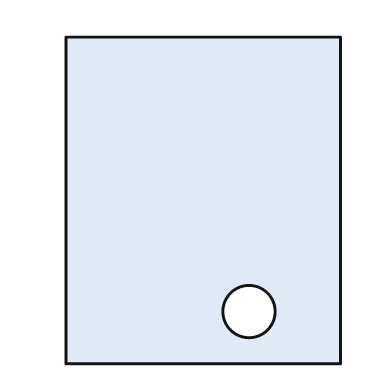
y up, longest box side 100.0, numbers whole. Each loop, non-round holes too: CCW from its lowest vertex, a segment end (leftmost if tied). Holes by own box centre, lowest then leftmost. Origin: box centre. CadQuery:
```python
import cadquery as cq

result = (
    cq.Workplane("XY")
    .moveTo(-42.0, -50.0)
    .lineTo(42.0, -50.0)
    .lineTo(42.0, 50.0)
    .lineTo(-42.0, 50.0)
    .close()
    .moveTo(14.0, -34.0)
    .circle(8.0)
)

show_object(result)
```